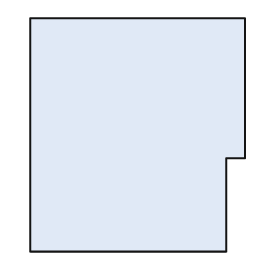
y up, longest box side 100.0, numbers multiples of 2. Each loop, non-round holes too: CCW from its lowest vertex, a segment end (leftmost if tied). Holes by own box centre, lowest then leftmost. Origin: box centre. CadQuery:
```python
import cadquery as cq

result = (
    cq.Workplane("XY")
    .moveTo(-46.0, -50.0)
    .lineTo(38.0, -50.0)
    .lineTo(38.0, -10.0)
    .lineTo(46.0, -10.0)
    .lineTo(46.0, 50.0)
    .lineTo(-46.0, 50.0)
    .close()
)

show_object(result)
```